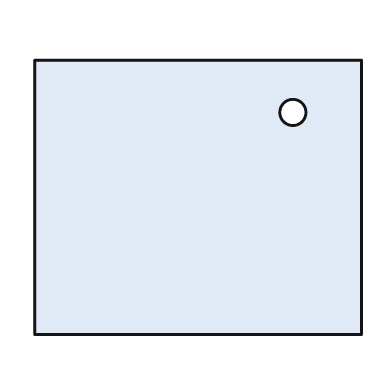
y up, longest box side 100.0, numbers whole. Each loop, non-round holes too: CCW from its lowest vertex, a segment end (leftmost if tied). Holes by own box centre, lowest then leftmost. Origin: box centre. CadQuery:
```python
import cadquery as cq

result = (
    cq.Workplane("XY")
    .moveTo(-50.0, -42.0)
    .lineTo(50.0, -42.0)
    .lineTo(50.0, 42.0)
    .lineTo(-50.0, 42.0)
    .close()
    .moveTo(29.0, 26.0)
    .circle(4.0)
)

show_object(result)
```